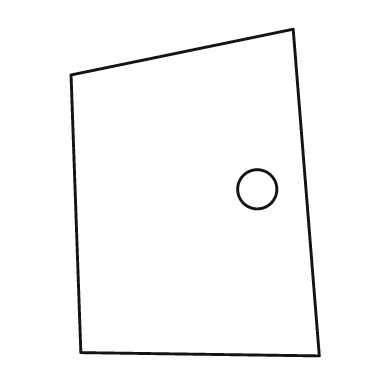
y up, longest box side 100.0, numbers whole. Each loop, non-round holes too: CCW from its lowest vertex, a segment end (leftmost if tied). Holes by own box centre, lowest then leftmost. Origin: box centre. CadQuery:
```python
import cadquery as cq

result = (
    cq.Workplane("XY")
    .moveTo(38.0, -50.0)
    .lineTo(30.0, 50.0)
    .lineTo(-38.0, 36.0)
    .lineTo(-35.0, -49.0)
    .close()
    .moveTo(19.0, 1.0)
    .circle(6.0)
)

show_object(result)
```